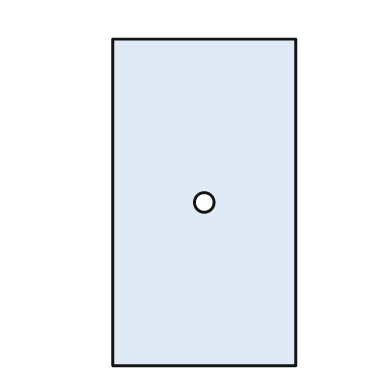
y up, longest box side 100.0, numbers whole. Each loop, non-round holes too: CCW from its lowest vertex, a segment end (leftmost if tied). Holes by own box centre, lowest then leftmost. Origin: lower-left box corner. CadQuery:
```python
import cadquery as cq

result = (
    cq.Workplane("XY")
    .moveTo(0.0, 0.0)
    .lineTo(56.0, 0.0)
    .lineTo(56.0, 100.0)
    .lineTo(0.0, 100.0)
    .close()
    .moveTo(28.0, 50.0)
    .circle(3.0)
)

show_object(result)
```